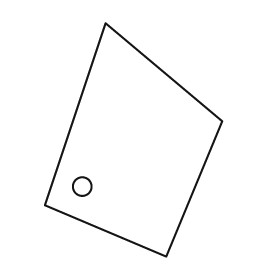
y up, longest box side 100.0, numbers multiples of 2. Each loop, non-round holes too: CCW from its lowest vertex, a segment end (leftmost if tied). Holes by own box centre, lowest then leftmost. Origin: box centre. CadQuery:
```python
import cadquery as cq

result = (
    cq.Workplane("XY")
    .moveTo(14.0, -50.0)
    .lineTo(38.0, 8.0)
    .lineTo(-12.0, 50.0)
    .lineTo(-38.0, -28.0)
    .close()
    .moveTo(-22.0, -20.0)
    .circle(4.0)
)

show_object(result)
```